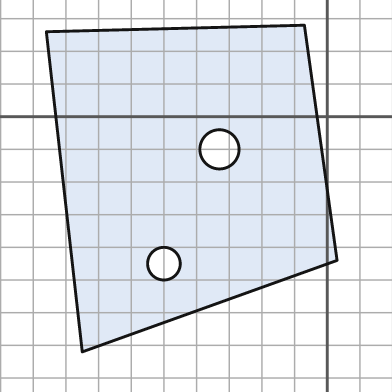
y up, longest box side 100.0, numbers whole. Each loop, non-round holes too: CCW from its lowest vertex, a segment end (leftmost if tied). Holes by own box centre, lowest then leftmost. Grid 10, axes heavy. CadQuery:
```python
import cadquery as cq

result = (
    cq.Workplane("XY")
    .moveTo(-75.0, -72.0)
    .lineTo(3.0, -44.0)
    .lineTo(-7.0, 28.0)
    .lineTo(-86.0, 26.0)
    .close()
    .moveTo(-50.0, -45.0)
    .circle(5.0)
    .moveTo(-33.0, -10.0)
    .circle(6.0)
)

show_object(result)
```